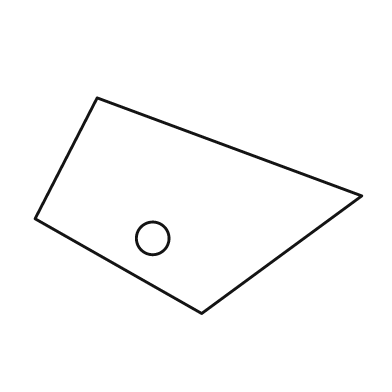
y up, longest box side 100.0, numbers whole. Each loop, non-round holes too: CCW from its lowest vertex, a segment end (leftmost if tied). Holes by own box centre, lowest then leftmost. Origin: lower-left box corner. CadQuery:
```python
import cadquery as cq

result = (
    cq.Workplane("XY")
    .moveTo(51.0, 0.0)
    .lineTo(100.0, 36.0)
    .lineTo(19.0, 66.0)
    .lineTo(0.0, 29.0)
    .close()
    .moveTo(36.0, 23.0)
    .circle(5.0)
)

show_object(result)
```